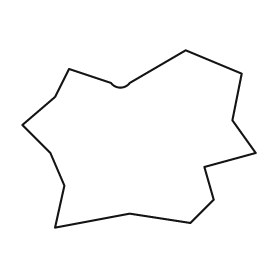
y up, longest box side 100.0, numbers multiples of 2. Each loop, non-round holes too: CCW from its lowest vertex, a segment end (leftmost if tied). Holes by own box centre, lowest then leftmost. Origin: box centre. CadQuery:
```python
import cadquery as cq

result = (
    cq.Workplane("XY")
    .moveTo(-36.0, -38.0)
    .lineTo(-4.0, -32.0)
    .lineTo(22.0, -36.0)
    .lineTo(32.0, -26.0)
    .lineTo(28.0, -12.0)
    .lineTo(50.0, -6.0)
    .lineTo(40.0, 8.0)
    .lineTo(44.0, 28.0)
    .lineTo(20.0, 38.0)
    .lineTo(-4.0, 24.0)
    .threePointArc((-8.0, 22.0), (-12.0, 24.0))
    .lineTo(-30.0, 30.0)
    .lineTo(-36.0, 18.0)
    .lineTo(-50.0, 6.0)
    .lineTo(-38.0, -6.0)
    .lineTo(-32.0, -20.0)
    .close()
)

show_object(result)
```